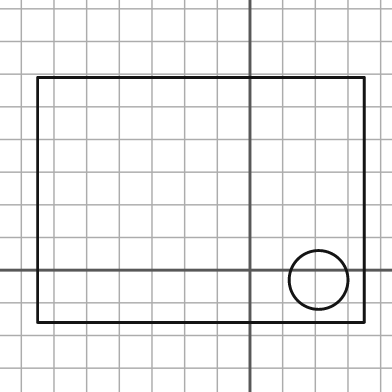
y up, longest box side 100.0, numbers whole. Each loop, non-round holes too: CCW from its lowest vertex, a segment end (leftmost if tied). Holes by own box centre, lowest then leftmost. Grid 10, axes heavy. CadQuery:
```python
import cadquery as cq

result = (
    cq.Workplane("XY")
    .moveTo(-65.0, -16.0)
    .lineTo(35.0, -16.0)
    .lineTo(35.0, 59.0)
    .lineTo(-65.0, 59.0)
    .close()
    .moveTo(21.0, -3.0)
    .circle(9.0)
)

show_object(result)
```